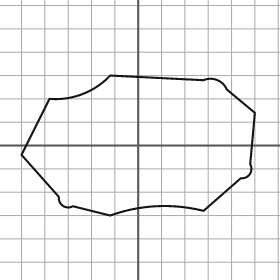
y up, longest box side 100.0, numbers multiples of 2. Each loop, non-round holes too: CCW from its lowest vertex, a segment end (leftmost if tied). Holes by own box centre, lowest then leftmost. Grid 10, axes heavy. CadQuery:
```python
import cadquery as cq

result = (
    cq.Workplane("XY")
    .moveTo(-12.0, -30.0)
    .threePointArc((8.0, -26.0), (28.0, -28.0))
    .lineTo(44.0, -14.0)
    .threePointArc((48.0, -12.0), (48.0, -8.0))
    .lineTo(50.0, 14.0)
    .lineTo(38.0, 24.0)
    .threePointArc((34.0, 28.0), (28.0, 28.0))
    .lineTo(-12.0, 30.0)
    .threePointArc((-24.0, 22.0), (-38.0, 20.0))
    .lineTo(-50.0, -4.0)
    .lineTo(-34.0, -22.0)
    .threePointArc((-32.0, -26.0), (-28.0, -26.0))
    .close()
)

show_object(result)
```